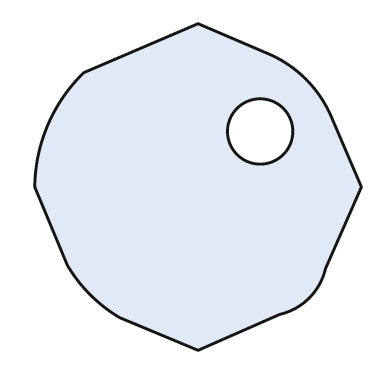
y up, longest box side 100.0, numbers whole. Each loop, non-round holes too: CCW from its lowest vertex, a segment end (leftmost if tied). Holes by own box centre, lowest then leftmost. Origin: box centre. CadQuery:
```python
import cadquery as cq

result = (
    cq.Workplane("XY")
    .moveTo(0.0, -50.0)
    .lineTo(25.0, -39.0)
    .threePointArc((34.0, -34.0), (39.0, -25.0))
    .lineTo(50.0, 0.0)
    .lineTo(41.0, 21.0)
    .threePointArc((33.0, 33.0), (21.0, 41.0))
    .lineTo(0.0, 50.0)
    .lineTo(-35.0, 35.0)
    .threePointArc((-46.0, 19.0), (-50.0, 0.0))
    .lineTo(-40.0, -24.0)
    .threePointArc((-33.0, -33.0), (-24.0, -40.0))
    .close()
    .moveTo(19.0, 17.0)
    .circle(10.0)
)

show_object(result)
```